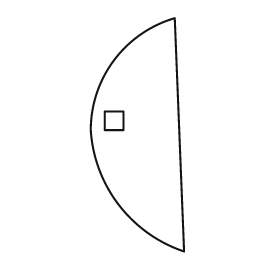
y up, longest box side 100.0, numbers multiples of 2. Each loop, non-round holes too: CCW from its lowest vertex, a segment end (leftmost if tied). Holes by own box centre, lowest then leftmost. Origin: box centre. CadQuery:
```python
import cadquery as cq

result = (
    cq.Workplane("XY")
    .moveTo(20.0, -50.0)
    .lineTo(16.0, 50.0)
    .threePointArc((-10.0, 32.0), (-20.0, 2.0))
    .threePointArc((-8.0, -30.0), (20.0, -50.0))
    .close()
    .moveTo(-14.0, 2.0)
    .lineTo(-6.0, 2.0)
    .lineTo(-6.0, 10.0)
    .lineTo(-14.0, 10.0)
    .close()
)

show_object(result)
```